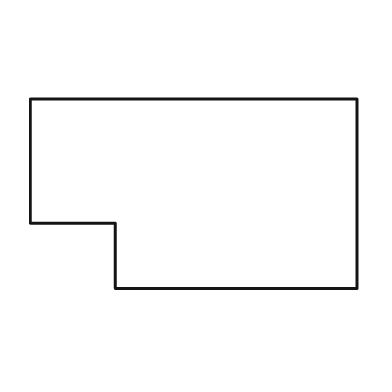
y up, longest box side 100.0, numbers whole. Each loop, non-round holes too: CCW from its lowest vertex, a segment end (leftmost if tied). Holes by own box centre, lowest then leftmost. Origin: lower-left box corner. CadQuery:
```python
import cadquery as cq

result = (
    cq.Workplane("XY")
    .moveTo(26.0, 0.0)
    .lineTo(100.0, 0.0)
    .lineTo(100.0, 58.0)
    .lineTo(0.0, 58.0)
    .lineTo(0.0, 20.0)
    .lineTo(26.0, 20.0)
    .close()
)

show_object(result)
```